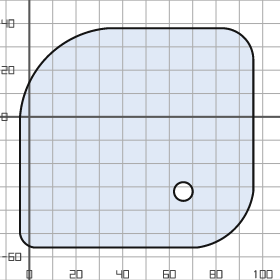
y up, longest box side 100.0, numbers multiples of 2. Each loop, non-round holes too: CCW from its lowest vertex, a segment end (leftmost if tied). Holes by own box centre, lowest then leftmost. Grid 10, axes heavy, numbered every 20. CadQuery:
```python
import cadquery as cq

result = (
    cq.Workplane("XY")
    .moveTo(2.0, -56.0)
    .lineTo(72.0, -56.0)
    .threePointArc((88.0, -48.0), (96.0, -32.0))
    .lineTo(96.0, 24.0)
    .threePointArc((92.0, 34.0), (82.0, 38.0))
    .lineTo(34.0, 38.0)
    .threePointArc((8.0, 26.0), (-4.0, 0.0))
    .lineTo(-4.0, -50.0)
    .threePointArc((-2.0, -54.0), (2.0, -56.0))
    .close()
    .moveTo(66.0, -32.0)
    .circle(4.0)
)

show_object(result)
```